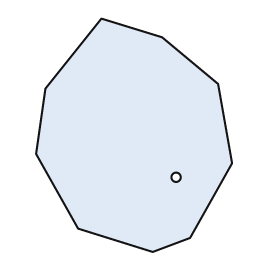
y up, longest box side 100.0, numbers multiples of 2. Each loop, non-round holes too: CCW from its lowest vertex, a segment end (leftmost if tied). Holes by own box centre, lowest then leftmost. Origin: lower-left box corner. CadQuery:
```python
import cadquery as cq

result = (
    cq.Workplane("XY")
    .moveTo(50.0, 0.0)
    .lineTo(66.0, 6.0)
    .lineTo(84.0, 38.0)
    .lineTo(78.0, 72.0)
    .lineTo(54.0, 92.0)
    .lineTo(28.0, 100.0)
    .lineTo(4.0, 70.0)
    .lineTo(0.0, 42.0)
    .lineTo(18.0, 10.0)
    .close()
    .moveTo(60.0, 32.0)
    .circle(2.0)
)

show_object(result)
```